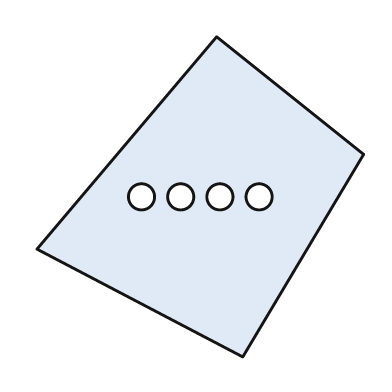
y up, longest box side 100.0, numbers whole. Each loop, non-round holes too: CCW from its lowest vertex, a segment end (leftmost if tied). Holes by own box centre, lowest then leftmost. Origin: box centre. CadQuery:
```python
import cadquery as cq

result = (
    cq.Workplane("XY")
    .moveTo(13.0, -49.0)
    .lineTo(50.0, 13.0)
    .lineTo(5.0, 49.0)
    .lineTo(-50.0, -16.0)
    .close()
    .moveTo(-18.0, 0.0)
    .circle(4.0)
    .moveTo(-6.0, 0.0)
    .circle(4.0)
    .moveTo(6.0, 0.0)
    .circle(4.0)
    .moveTo(18.0, 0.0)
    .circle(4.0)
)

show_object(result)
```